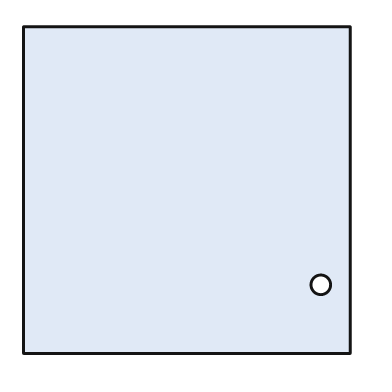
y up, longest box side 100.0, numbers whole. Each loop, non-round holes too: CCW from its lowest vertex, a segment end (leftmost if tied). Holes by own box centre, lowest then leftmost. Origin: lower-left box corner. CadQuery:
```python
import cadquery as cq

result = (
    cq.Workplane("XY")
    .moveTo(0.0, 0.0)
    .lineTo(100.0, 0.0)
    .lineTo(100.0, 100.0)
    .lineTo(0.0, 100.0)
    .close()
    .moveTo(91.0, 21.0)
    .circle(3.0)
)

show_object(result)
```